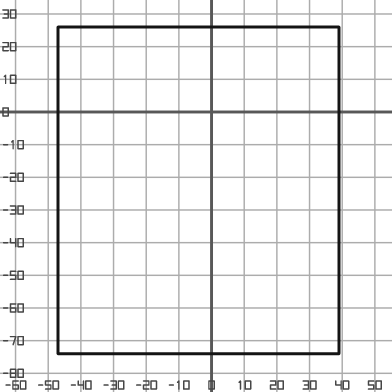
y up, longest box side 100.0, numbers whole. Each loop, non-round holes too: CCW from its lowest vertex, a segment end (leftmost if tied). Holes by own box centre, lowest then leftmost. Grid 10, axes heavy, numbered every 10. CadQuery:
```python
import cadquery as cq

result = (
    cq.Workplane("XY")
    .moveTo(-47.0, -74.0)
    .lineTo(39.0, -74.0)
    .lineTo(39.0, 26.0)
    .lineTo(-47.0, 26.0)
    .close()
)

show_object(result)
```